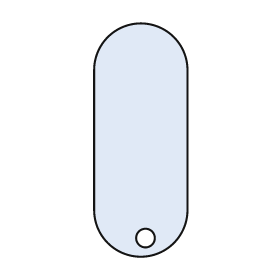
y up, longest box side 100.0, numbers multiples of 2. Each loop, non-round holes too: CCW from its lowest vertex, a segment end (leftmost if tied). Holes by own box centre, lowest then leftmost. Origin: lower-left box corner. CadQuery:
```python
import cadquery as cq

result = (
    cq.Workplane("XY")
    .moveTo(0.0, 20.0)
    .threePointArc((20.0, 0.0), (40.0, 20.0))
    .lineTo(40.0, 80.0)
    .threePointArc((20.0, 100.0), (0.0, 80.0))
    .close()
    .moveTo(22.0, 8.0)
    .circle(4.0)
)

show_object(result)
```